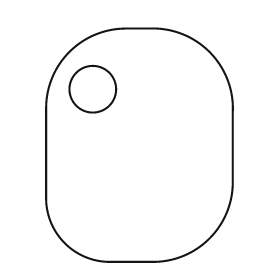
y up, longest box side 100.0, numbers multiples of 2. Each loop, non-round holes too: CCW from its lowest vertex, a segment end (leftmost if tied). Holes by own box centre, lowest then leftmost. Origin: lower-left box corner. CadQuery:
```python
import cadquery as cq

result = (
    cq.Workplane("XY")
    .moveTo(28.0, 0.0)
    .lineTo(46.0, 0.0)
    .threePointArc((70.0, 10.0), (80.0, 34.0))
    .lineTo(80.0, 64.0)
    .threePointArc((70.0, 90.0), (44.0, 100.0))
    .lineTo(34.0, 100.0)
    .threePointArc((10.0, 90.0), (0.0, 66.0))
    .lineTo(0.0, 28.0)
    .threePointArc((8.0, 8.0), (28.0, 0.0))
    .close()
    .moveTo(20.0, 74.0)
    .circle(10.0)
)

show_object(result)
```